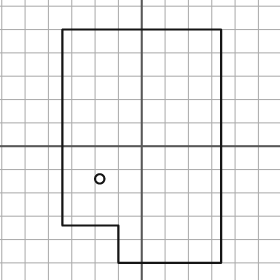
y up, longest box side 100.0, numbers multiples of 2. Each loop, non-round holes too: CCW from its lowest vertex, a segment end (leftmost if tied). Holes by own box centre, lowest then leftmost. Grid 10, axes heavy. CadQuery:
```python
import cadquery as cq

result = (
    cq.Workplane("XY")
    .moveTo(-10.0, -50.0)
    .lineTo(34.0, -50.0)
    .lineTo(34.0, 50.0)
    .lineTo(-34.0, 50.0)
    .lineTo(-34.0, -34.0)
    .lineTo(-10.0, -34.0)
    .close()
    .moveTo(-18.0, -14.0)
    .circle(2.0)
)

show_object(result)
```